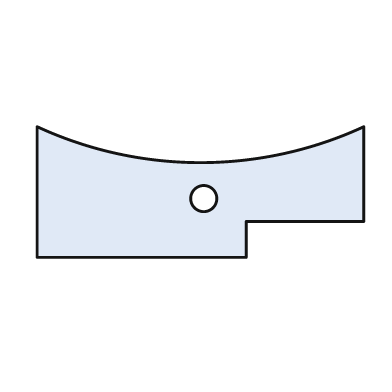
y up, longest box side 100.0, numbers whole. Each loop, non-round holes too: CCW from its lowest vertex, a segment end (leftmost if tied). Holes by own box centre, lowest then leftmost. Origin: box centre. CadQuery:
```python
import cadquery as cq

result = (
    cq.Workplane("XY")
    .moveTo(-50.0, -20.0)
    .lineTo(14.0, -20.0)
    .lineTo(14.0, -9.0)
    .lineTo(50.0, -9.0)
    .lineTo(50.0, 20.0)
    .threePointArc((0.0, 9.0), (-50.0, 20.0))
    .close()
    .moveTo(1.0, -2.0)
    .circle(4.0)
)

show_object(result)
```